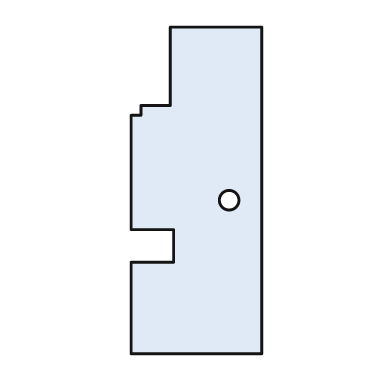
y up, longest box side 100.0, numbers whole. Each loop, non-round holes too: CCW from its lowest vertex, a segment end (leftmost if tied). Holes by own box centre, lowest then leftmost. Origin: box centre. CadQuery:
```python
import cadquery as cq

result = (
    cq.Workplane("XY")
    .moveTo(-20.0, -50.0)
    .lineTo(20.0, -50.0)
    .lineTo(20.0, 50.0)
    .lineTo(-8.0, 50.0)
    .lineTo(-8.0, 26.0)
    .lineTo(-17.0, 26.0)
    .lineTo(-17.0, 23.0)
    .lineTo(-20.0, 23.0)
    .lineTo(-20.0, -12.0)
    .lineTo(-7.0, -12.0)
    .lineTo(-7.0, -22.0)
    .lineTo(-20.0, -22.0)
    .close()
    .moveTo(10.0, -3.0)
    .circle(3.0)
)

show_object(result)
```